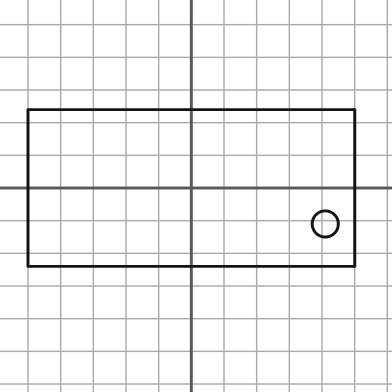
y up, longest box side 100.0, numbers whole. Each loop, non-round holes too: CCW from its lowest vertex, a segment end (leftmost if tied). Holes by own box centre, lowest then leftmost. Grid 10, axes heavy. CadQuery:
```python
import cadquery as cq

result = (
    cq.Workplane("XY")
    .moveTo(-50.0, -24.0)
    .lineTo(50.0, -24.0)
    .lineTo(50.0, 24.0)
    .lineTo(-50.0, 24.0)
    .close()
    .moveTo(41.0, -11.0)
    .circle(4.0)
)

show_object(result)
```